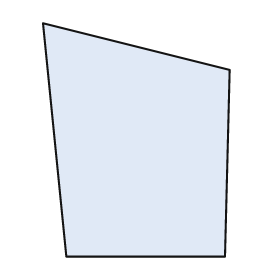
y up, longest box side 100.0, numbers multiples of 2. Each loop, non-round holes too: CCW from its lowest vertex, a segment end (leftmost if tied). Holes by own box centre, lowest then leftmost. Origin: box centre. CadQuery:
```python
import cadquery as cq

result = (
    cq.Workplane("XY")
    .moveTo(-30.0, -50.0)
    .lineTo(38.0, -50.0)
    .lineTo(40.0, 30.0)
    .lineTo(-40.0, 50.0)
    .close()
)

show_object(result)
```